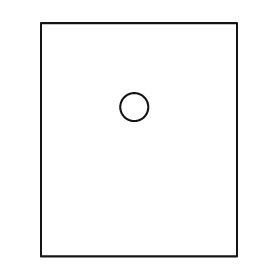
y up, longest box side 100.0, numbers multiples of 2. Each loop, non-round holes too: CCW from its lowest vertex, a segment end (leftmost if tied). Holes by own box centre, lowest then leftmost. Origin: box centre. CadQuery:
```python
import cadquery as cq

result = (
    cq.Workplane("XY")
    .moveTo(-42.0, -50.0)
    .lineTo(42.0, -50.0)
    .lineTo(42.0, 50.0)
    .lineTo(-42.0, 50.0)
    .close()
    .moveTo(-2.0, 14.0)
    .circle(6.0)
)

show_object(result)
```